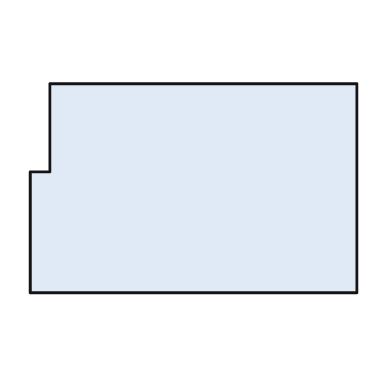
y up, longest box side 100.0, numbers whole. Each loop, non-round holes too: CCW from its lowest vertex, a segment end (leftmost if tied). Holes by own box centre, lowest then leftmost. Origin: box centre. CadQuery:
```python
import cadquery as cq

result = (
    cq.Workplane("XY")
    .moveTo(-50.0, -32.0)
    .lineTo(50.0, -32.0)
    .lineTo(50.0, 32.0)
    .lineTo(-44.0, 32.0)
    .lineTo(-44.0, 5.0)
    .lineTo(-50.0, 5.0)
    .close()
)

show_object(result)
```